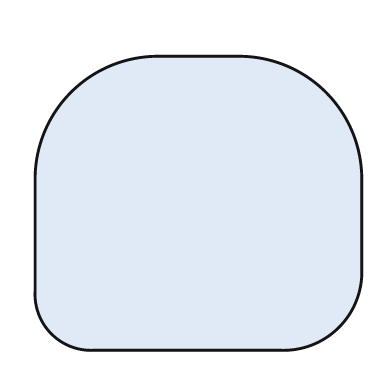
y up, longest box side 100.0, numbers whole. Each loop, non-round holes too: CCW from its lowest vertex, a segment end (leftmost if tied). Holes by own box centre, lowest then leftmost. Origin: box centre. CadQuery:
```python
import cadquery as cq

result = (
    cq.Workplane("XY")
    .moveTo(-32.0, -45.0)
    .lineTo(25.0, -45.0)
    .threePointArc((43.0, -38.0), (50.0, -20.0))
    .lineTo(50.0, 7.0)
    .threePointArc((39.0, 34.0), (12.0, 45.0))
    .lineTo(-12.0, 45.0)
    .threePointArc((-39.0, 34.0), (-50.0, 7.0))
    .lineTo(-50.0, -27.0)
    .threePointArc((-45.0, -40.0), (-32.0, -45.0))
    .close()
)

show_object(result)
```